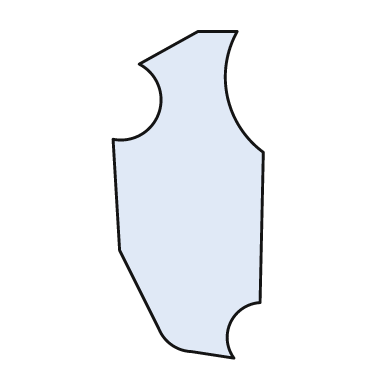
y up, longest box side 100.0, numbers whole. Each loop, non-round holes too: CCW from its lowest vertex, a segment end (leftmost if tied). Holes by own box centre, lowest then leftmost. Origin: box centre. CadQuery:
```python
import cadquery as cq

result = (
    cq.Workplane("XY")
    .moveTo(14.0, -50.0)
    .threePointArc((13.0, -39.0), (22.0, -33.0))
    .lineTo(23.0, 13.0)
    .threePointArc((12.0, 30.0), (15.0, 50.0))
    .lineTo(3.0, 50.0)
    .lineTo(-15.0, 40.0)
    .threePointArc((-9.0, 25.0), (-23.0, 17.0))
    .lineTo(-21.0, -17.0)
    .lineTo(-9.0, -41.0)
    .threePointArc((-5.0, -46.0), (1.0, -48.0))
    .close()
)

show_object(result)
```